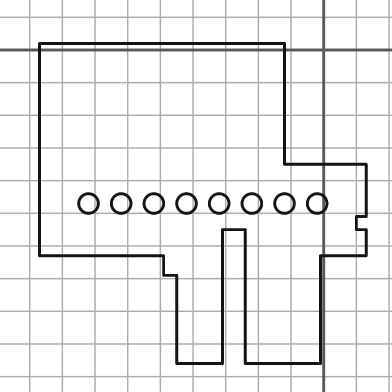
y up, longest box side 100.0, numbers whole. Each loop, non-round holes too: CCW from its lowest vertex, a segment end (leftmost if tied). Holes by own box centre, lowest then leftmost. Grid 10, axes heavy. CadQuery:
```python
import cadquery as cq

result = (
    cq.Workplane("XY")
    .moveTo(-45.0, -96.0)
    .lineTo(-31.0, -96.0)
    .lineTo(-31.0, -55.0)
    .lineTo(-24.0, -55.0)
    .lineTo(-24.0, -96.0)
    .lineTo(-1.0, -96.0)
    .lineTo(-1.0, -63.0)
    .lineTo(13.0, -63.0)
    .lineTo(13.0, -55.0)
    .lineTo(10.0, -55.0)
    .lineTo(10.0, -51.0)
    .lineTo(13.0, -51.0)
    .lineTo(13.0, -35.0)
    .lineTo(-12.0, -35.0)
    .lineTo(-12.0, 2.0)
    .lineTo(-87.0, 2.0)
    .lineTo(-87.0, -63.0)
    .lineTo(-49.0, -63.0)
    .lineTo(-49.0, -69.0)
    .lineTo(-45.0, -69.0)
    .close()
    .moveTo(-72.0, -47.0)
    .circle(3.0)
    .moveTo(-62.0, -47.0)
    .circle(3.0)
    .moveTo(-52.0, -47.0)
    .circle(3.0)
    .moveTo(-42.0, -47.0)
    .circle(3.0)
    .moveTo(-32.0, -47.0)
    .circle(3.0)
    .moveTo(-22.0, -47.0)
    .circle(3.0)
    .moveTo(-12.0, -47.0)
    .circle(3.0)
    .moveTo(-2.0, -47.0)
    .circle(3.0)
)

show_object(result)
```